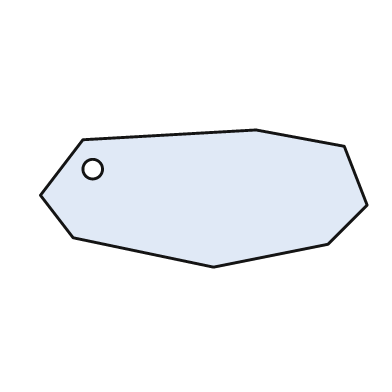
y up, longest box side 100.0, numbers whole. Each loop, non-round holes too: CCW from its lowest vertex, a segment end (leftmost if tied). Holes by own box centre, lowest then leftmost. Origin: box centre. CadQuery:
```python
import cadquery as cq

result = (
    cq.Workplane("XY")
    .moveTo(3.0, -21.0)
    .lineTo(38.0, -14.0)
    .lineTo(50.0, -2.0)
    .lineTo(43.0, 16.0)
    .lineTo(16.0, 21.0)
    .lineTo(-37.0, 18.0)
    .lineTo(-50.0, 1.0)
    .lineTo(-40.0, -12.0)
    .close()
    .moveTo(-34.0, 9.0)
    .circle(3.0)
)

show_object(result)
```